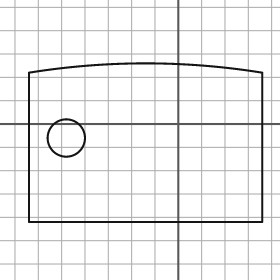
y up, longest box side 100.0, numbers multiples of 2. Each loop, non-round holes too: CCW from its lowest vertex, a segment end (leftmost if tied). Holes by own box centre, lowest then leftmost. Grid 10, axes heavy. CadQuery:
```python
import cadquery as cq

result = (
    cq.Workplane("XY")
    .moveTo(-64.0, -42.0)
    .lineTo(36.0, -42.0)
    .lineTo(36.0, 22.0)
    .threePointArc((-14.0, 26.0), (-64.0, 22.0))
    .close()
    .moveTo(-48.0, -6.0)
    .circle(8.0)
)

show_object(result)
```